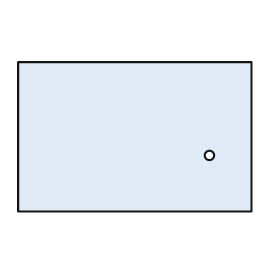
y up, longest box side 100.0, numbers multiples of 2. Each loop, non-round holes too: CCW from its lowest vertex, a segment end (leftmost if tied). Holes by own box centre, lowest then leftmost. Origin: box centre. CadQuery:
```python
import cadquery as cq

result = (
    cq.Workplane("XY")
    .moveTo(-50.0, -32.0)
    .lineTo(50.0, -32.0)
    .lineTo(50.0, 32.0)
    .lineTo(-50.0, 32.0)
    .close()
    .moveTo(32.0, -8.0)
    .circle(2.0)
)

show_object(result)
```